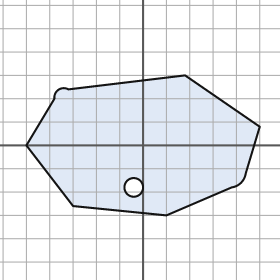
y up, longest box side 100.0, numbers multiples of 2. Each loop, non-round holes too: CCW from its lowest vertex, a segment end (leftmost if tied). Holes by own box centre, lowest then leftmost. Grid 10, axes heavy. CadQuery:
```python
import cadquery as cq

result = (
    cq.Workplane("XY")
    .moveTo(10.0, -30.0)
    .lineTo(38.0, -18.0)
    .threePointArc((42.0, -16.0), (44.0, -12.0))
    .lineTo(50.0, 8.0)
    .lineTo(18.0, 30.0)
    .lineTo(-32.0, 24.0)
    .threePointArc((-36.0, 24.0), (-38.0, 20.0))
    .lineTo(-50.0, 0.0)
    .lineTo(-30.0, -26.0)
    .close()
    .moveTo(-4.0, -18.0)
    .circle(4.0)
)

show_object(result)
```